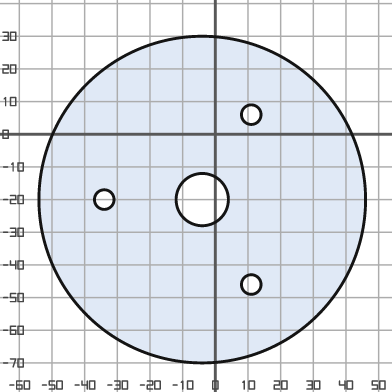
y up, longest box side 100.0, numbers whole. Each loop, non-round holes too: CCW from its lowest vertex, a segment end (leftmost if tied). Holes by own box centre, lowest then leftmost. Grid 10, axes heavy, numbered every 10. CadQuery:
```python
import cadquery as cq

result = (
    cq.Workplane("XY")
    .moveTo(-4.0, -20.0)
    .circle(50.0)
    .moveTo(11.0, -46.0)
    .circle(3.0)
    .moveTo(-34.0, -20.0)
    .circle(3.0)
    .moveTo(-4.0, -20.0)
    .circle(8.0)
    .moveTo(11.0, 6.0)
    .circle(3.0)
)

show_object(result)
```